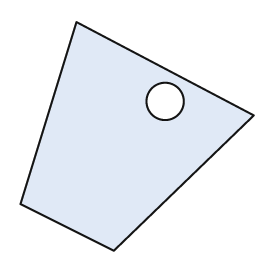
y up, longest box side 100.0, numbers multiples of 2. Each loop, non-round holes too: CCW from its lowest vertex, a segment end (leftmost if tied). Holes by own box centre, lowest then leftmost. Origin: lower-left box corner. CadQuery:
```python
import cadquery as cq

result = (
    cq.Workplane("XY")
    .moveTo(40.0, 0.0)
    .lineTo(100.0, 58.0)
    .lineTo(24.0, 98.0)
    .lineTo(0.0, 20.0)
    .close()
    .moveTo(62.0, 64.0)
    .circle(8.0)
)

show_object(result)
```